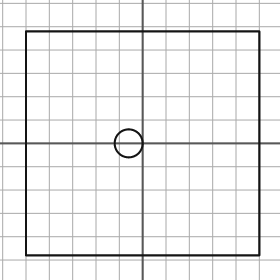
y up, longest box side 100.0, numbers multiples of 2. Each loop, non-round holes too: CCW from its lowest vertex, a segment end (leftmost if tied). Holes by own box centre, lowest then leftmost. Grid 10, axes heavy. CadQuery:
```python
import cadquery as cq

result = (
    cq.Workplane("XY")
    .moveTo(-50.0, -48.0)
    .lineTo(50.0, -48.0)
    .lineTo(50.0, 48.0)
    .lineTo(-50.0, 48.0)
    .close()
    .moveTo(-6.0, 0.0)
    .circle(6.0)
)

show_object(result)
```